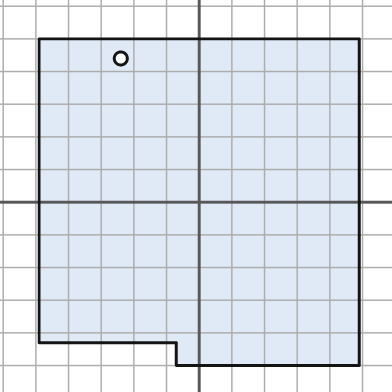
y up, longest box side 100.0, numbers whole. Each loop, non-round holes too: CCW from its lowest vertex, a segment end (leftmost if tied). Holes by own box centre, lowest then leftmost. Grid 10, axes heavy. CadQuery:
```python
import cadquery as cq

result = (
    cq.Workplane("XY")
    .moveTo(-7.0, -50.0)
    .lineTo(49.0, -50.0)
    .lineTo(49.0, 50.0)
    .lineTo(-49.0, 50.0)
    .lineTo(-49.0, -43.0)
    .lineTo(-7.0, -43.0)
    .close()
    .moveTo(-24.0, 44.0)
    .circle(2.0)
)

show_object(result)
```